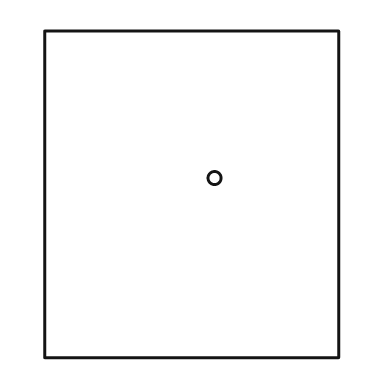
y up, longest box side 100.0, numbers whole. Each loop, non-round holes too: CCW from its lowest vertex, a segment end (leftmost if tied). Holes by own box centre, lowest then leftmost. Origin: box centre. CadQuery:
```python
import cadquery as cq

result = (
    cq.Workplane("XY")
    .moveTo(-45.0, -50.0)
    .lineTo(45.0, -50.0)
    .lineTo(45.0, 50.0)
    .lineTo(-45.0, 50.0)
    .close()
    .moveTo(7.0, 5.0)
    .circle(2.0)
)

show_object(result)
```